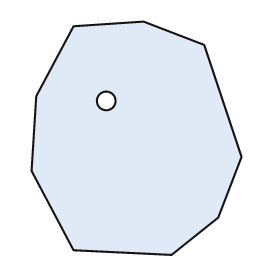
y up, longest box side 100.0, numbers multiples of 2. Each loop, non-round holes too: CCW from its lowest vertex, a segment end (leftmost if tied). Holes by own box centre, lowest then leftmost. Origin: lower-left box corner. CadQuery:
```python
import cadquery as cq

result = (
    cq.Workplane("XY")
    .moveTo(60.0, 0.0)
    .lineTo(80.0, 16.0)
    .lineTo(90.0, 42.0)
    .lineTo(74.0, 90.0)
    .lineTo(48.0, 100.0)
    .lineTo(18.0, 98.0)
    .lineTo(2.0, 68.0)
    .lineTo(0.0, 36.0)
    .lineTo(18.0, 2.0)
    .close()
    .moveTo(32.0, 66.0)
    .circle(4.0)
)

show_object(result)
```